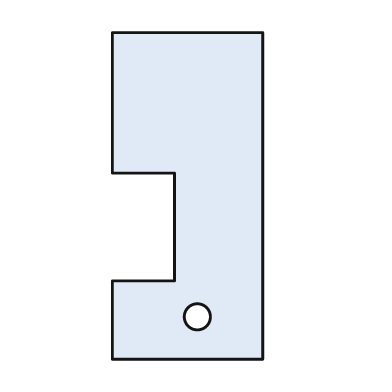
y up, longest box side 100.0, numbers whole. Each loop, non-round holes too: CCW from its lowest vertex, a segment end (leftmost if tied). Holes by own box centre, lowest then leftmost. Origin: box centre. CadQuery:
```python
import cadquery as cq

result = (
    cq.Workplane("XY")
    .moveTo(-23.0, -50.0)
    .lineTo(23.0, -50.0)
    .lineTo(23.0, 50.0)
    .lineTo(-23.0, 50.0)
    .lineTo(-23.0, 7.0)
    .lineTo(-4.0, 7.0)
    .lineTo(-4.0, -26.0)
    .lineTo(-23.0, -26.0)
    .close()
    .moveTo(3.0, -37.0)
    .circle(4.0)
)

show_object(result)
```